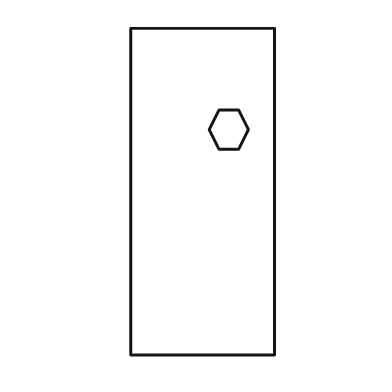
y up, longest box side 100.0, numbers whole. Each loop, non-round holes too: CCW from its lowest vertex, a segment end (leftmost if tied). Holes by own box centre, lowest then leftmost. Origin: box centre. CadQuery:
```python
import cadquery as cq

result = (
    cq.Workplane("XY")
    .moveTo(-22.0, -50.0)
    .lineTo(22.0, -50.0)
    .lineTo(22.0, 50.0)
    .lineTo(-22.0, 50.0)
    .close()
    .moveTo(5.0, 13.0)
    .lineTo(11.0, 13.0)
    .lineTo(14.0, 19.0)
    .lineTo(11.0, 25.0)
    .lineTo(5.0, 25.0)
    .lineTo(2.0, 19.0)
    .close()
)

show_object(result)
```